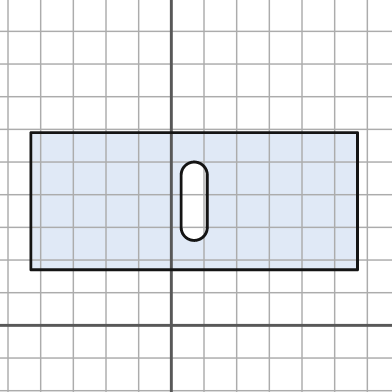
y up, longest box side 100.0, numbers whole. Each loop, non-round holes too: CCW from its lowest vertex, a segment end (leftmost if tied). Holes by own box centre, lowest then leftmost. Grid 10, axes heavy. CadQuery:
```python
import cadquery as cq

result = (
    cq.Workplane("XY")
    .moveTo(-43.0, 17.0)
    .lineTo(57.0, 17.0)
    .lineTo(57.0, 59.0)
    .lineTo(-43.0, 59.0)
    .close()
    .moveTo(3.0, 30.0)
    .threePointArc((7.0, 26.0), (11.0, 30.0))
    .lineTo(11.0, 46.0)
    .threePointArc((7.0, 50.0), (3.0, 46.0))
    .close()
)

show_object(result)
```